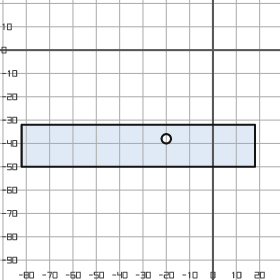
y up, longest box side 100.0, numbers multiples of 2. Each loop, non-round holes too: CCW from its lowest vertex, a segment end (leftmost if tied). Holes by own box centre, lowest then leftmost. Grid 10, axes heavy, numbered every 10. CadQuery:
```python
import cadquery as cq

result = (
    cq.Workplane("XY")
    .moveTo(-82.0, -50.0)
    .lineTo(18.0, -50.0)
    .lineTo(18.0, -32.0)
    .lineTo(-82.0, -32.0)
    .close()
    .moveTo(-20.0, -38.0)
    .circle(2.0)
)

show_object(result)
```